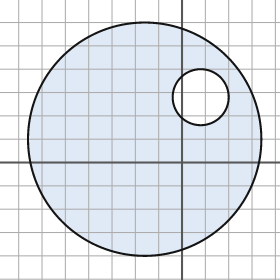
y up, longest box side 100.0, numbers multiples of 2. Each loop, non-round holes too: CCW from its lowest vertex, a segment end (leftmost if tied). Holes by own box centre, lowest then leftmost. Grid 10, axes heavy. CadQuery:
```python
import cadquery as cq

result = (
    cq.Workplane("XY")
    .moveTo(-16.0, 10.0)
    .circle(50.0)
    .moveTo(8.0, 28.0)
    .circle(12.0)
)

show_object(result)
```